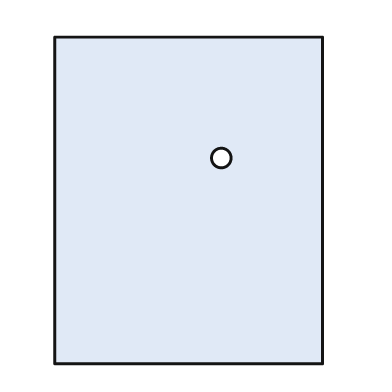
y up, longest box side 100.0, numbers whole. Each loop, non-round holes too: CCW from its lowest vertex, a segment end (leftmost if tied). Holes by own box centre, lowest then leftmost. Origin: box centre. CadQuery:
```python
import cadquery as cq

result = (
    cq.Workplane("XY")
    .moveTo(-41.0, -50.0)
    .lineTo(41.0, -50.0)
    .lineTo(41.0, 50.0)
    .lineTo(-41.0, 50.0)
    .close()
    .moveTo(10.0, 13.0)
    .circle(3.0)
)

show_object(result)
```